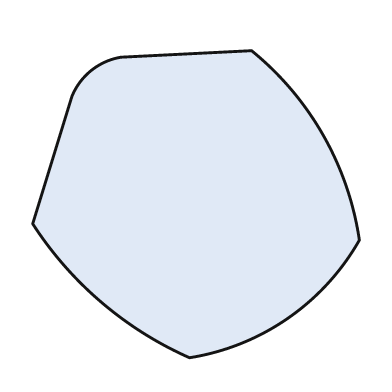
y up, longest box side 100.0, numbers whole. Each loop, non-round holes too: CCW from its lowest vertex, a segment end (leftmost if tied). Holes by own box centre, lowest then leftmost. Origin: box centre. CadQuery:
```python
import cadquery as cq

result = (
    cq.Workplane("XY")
    .moveTo(-2.0, -47.0)
    .threePointArc((28.0, -35.0), (50.0, -11.0))
    .threePointArc((39.0, 21.0), (17.0, 47.0))
    .lineTo(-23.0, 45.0)
    .threePointArc((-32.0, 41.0), (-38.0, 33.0))
    .lineTo(-50.0, -6.0)
    .threePointArc((-29.0, -30.0), (-2.0, -47.0))
    .close()
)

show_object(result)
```